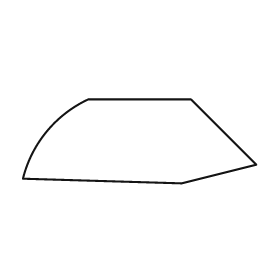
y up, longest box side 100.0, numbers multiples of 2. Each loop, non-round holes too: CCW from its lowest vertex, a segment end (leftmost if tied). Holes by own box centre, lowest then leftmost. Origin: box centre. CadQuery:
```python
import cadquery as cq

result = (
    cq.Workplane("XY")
    .moveTo(18.0, -18.0)
    .lineTo(50.0, -10.0)
    .lineTo(22.0, 18.0)
    .lineTo(-22.0, 18.0)
    .threePointArc((-40.0, 4.0), (-50.0, -16.0))
    .close()
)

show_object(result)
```